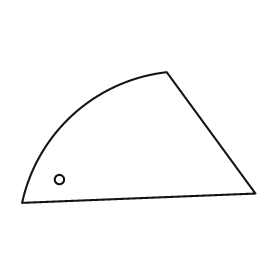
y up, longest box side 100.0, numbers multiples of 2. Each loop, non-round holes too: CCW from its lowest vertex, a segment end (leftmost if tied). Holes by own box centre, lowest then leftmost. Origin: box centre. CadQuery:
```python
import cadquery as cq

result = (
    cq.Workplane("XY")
    .moveTo(-50.0, -28.0)
    .lineTo(50.0, -24.0)
    .lineTo(12.0, 28.0)
    .threePointArc((-28.0, 10.0), (-50.0, -28.0))
    .close()
    .moveTo(-34.0, -18.0)
    .circle(2.0)
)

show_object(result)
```